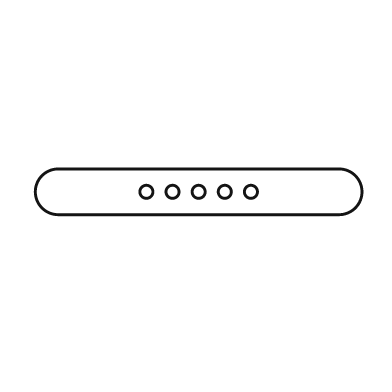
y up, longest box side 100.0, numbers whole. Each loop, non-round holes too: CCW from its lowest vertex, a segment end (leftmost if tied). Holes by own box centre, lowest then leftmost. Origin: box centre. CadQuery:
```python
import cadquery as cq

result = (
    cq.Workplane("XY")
    .moveTo(-43.0, -7.0)
    .lineTo(43.0, -7.0)
    .threePointArc((50.0, 0.0), (43.0, 7.0))
    .lineTo(-43.0, 7.0)
    .threePointArc((-50.0, 0.0), (-43.0, -7.0))
    .close()
    .moveTo(-16.0, 0.0)
    .circle(2.0)
    .moveTo(-8.0, 0.0)
    .circle(2.0)
    .moveTo(0.0, 0.0)
    .circle(2.0)
    .moveTo(8.0, 0.0)
    .circle(2.0)
    .moveTo(16.0, 0.0)
    .circle(2.0)
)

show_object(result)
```